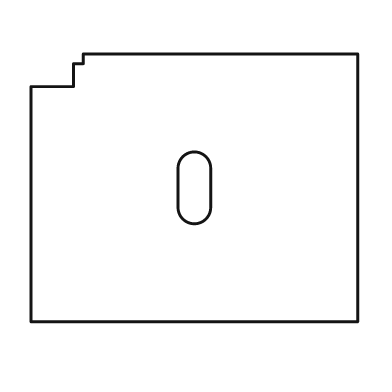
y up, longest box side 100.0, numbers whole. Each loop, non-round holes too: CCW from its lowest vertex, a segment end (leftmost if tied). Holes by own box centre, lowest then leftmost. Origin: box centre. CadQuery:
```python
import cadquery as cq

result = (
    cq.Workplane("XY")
    .moveTo(-50.0, -41.0)
    .lineTo(50.0, -41.0)
    .lineTo(50.0, 41.0)
    .lineTo(-34.0, 41.0)
    .lineTo(-34.0, 38.0)
    .lineTo(-37.0, 38.0)
    .lineTo(-37.0, 31.0)
    .lineTo(-50.0, 31.0)
    .close()
    .moveTo(-5.0, -6.0)
    .threePointArc((0.0, -11.0), (5.0, -6.0))
    .lineTo(5.0, 6.0)
    .threePointArc((0.0, 11.0), (-5.0, 6.0))
    .close()
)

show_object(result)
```